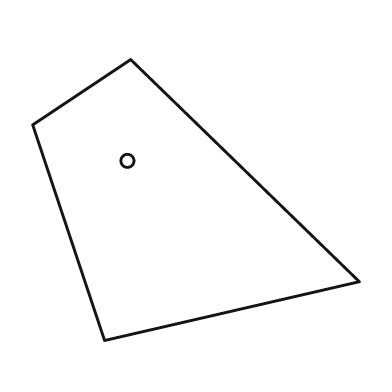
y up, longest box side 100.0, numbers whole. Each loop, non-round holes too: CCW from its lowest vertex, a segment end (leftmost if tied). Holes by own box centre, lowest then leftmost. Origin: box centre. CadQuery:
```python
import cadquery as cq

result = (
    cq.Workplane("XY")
    .moveTo(-28.0, -43.0)
    .lineTo(50.0, -25.0)
    .lineTo(-20.0, 43.0)
    .lineTo(-50.0, 23.0)
    .close()
    .moveTo(-21.0, 12.0)
    .circle(2.0)
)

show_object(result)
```